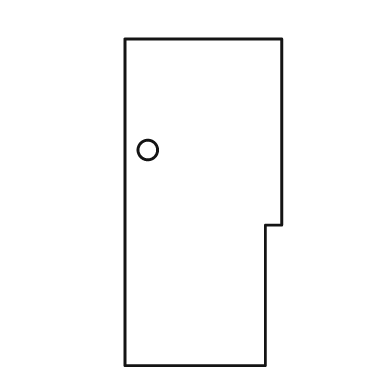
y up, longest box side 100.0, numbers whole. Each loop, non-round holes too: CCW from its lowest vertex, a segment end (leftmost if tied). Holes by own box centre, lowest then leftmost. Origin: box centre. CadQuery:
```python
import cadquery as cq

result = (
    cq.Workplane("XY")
    .moveTo(-24.0, -50.0)
    .lineTo(19.0, -50.0)
    .lineTo(19.0, -7.0)
    .lineTo(24.0, -7.0)
    .lineTo(24.0, 50.0)
    .lineTo(-24.0, 50.0)
    .close()
    .moveTo(-17.0, 16.0)
    .circle(3.0)
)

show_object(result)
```